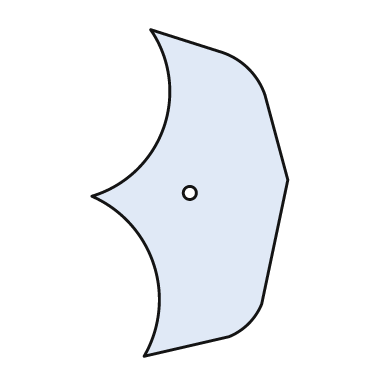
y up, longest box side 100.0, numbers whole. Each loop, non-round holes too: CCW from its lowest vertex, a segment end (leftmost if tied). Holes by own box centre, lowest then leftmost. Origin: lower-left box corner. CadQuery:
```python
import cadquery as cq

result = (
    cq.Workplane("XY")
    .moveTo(16.0, 0.0)
    .lineTo(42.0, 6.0)
    .threePointArc((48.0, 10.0), (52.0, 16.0))
    .lineTo(60.0, 54.0)
    .lineTo(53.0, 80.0)
    .threePointArc((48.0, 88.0), (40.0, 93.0))
    .lineTo(18.0, 100.0)
    .threePointArc((22.0, 70.0), (0.0, 49.0))
    .threePointArc((19.0, 28.0), (16.0, 0.0))
    .close()
    .moveTo(30.0, 50.0)
    .circle(2.0)
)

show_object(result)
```